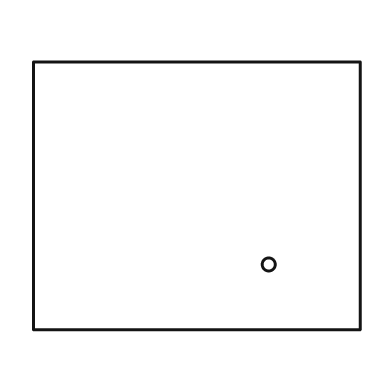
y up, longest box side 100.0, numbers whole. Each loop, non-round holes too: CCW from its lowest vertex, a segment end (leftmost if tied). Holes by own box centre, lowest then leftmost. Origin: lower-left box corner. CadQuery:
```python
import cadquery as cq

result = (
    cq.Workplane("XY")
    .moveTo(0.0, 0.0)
    .lineTo(100.0, 0.0)
    .lineTo(100.0, 82.0)
    .lineTo(0.0, 82.0)
    .close()
    .moveTo(72.0, 20.0)
    .circle(2.0)
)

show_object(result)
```